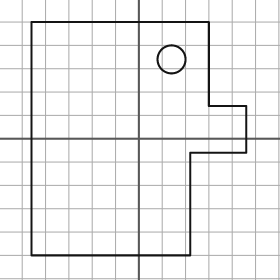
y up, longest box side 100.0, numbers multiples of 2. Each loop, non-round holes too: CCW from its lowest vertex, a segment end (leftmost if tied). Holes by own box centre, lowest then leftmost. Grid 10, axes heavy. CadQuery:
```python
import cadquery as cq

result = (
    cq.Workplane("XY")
    .moveTo(-46.0, -50.0)
    .lineTo(22.0, -50.0)
    .lineTo(22.0, -6.0)
    .lineTo(46.0, -6.0)
    .lineTo(46.0, 14.0)
    .lineTo(30.0, 14.0)
    .lineTo(30.0, 50.0)
    .lineTo(-46.0, 50.0)
    .close()
    .moveTo(14.0, 34.0)
    .circle(6.0)
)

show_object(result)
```